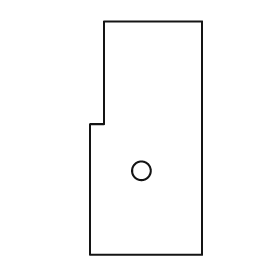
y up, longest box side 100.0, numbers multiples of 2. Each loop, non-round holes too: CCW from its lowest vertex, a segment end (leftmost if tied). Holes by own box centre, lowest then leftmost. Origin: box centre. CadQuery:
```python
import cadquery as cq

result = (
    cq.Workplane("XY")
    .moveTo(-24.0, -50.0)
    .lineTo(24.0, -50.0)
    .lineTo(24.0, 50.0)
    .lineTo(-18.0, 50.0)
    .lineTo(-18.0, 6.0)
    .lineTo(-24.0, 6.0)
    .close()
    .moveTo(-2.0, -14.0)
    .circle(4.0)
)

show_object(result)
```